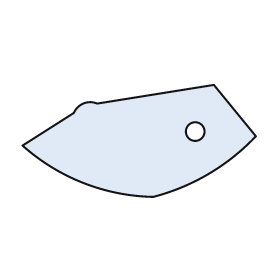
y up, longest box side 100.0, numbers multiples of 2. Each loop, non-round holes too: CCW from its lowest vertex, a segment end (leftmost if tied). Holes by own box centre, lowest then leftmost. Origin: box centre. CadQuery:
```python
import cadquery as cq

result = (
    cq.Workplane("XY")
    .moveTo(6.0, -24.0)
    .threePointArc((30.0, -14.0), (50.0, 2.0))
    .lineTo(32.0, 24.0)
    .lineTo(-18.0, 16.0)
    .threePointArc((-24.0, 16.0), (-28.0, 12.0))
    .lineTo(-50.0, -2.0)
    .threePointArc((-24.0, -18.0), (6.0, -24.0))
    .close()
    .moveTo(24.0, 4.0)
    .circle(4.0)
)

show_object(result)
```